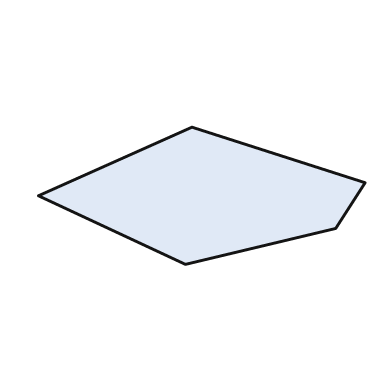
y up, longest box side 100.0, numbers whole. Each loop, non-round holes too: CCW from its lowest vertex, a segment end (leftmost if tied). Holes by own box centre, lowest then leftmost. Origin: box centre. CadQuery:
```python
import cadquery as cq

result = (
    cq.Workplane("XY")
    .moveTo(-5.0, -21.0)
    .lineTo(41.0, -10.0)
    .lineTo(50.0, 4.0)
    .lineTo(-3.0, 21.0)
    .lineTo(-50.0, 0.0)
    .close()
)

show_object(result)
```